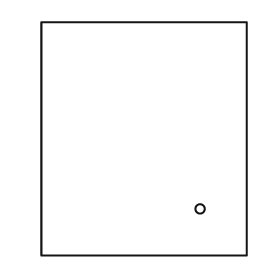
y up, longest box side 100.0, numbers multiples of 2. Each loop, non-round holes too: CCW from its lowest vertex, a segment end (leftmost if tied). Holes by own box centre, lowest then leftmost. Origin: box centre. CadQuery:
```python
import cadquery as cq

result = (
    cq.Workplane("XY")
    .moveTo(-44.0, -50.0)
    .lineTo(44.0, -50.0)
    .lineTo(44.0, 50.0)
    .lineTo(-44.0, 50.0)
    .close()
    .moveTo(24.0, -30.0)
    .circle(2.0)
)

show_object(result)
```